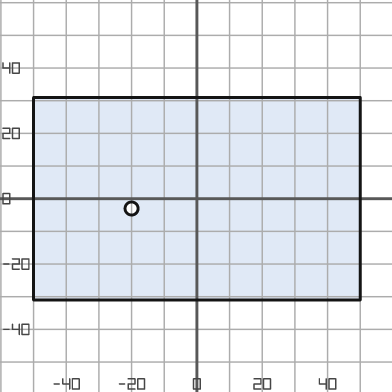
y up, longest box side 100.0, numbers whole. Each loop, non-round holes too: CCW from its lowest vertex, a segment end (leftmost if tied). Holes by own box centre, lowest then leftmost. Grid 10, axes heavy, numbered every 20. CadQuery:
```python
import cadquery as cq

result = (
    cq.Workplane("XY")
    .moveTo(-50.0, -31.0)
    .lineTo(50.0, -31.0)
    .lineTo(50.0, 31.0)
    .lineTo(-50.0, 31.0)
    .close()
    .moveTo(-20.0, -3.0)
    .circle(2.0)
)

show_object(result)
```